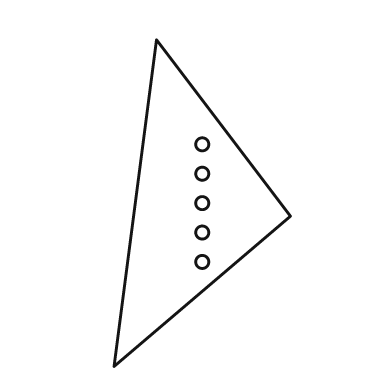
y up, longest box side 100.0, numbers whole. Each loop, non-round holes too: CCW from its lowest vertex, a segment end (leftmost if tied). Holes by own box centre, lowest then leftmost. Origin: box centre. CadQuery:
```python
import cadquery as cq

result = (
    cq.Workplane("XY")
    .moveTo(-27.0, -50.0)
    .lineTo(27.0, -4.0)
    .lineTo(-14.0, 50.0)
    .close()
    .moveTo(0.0, -18.0)
    .circle(2.0)
    .moveTo(0.0, -9.0)
    .circle(2.0)
    .moveTo(0.0, 0.0)
    .circle(2.0)
    .moveTo(0.0, 9.0)
    .circle(2.0)
    .moveTo(0.0, 18.0)
    .circle(2.0)
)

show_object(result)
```